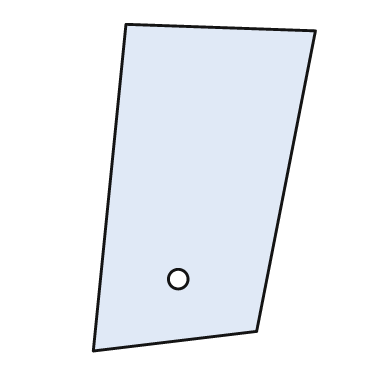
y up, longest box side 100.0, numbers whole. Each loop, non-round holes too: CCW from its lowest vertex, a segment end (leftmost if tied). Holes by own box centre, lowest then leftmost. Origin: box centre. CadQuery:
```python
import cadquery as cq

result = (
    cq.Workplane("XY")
    .moveTo(-34.0, -50.0)
    .lineTo(16.0, -44.0)
    .lineTo(34.0, 48.0)
    .lineTo(-24.0, 50.0)
    .close()
    .moveTo(-8.0, -28.0)
    .circle(3.0)
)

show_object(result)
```